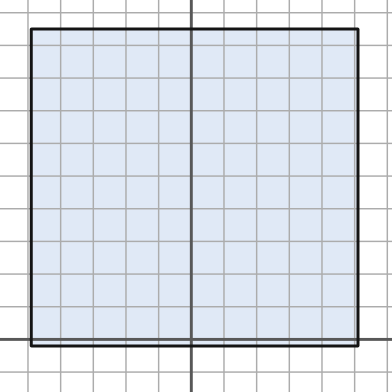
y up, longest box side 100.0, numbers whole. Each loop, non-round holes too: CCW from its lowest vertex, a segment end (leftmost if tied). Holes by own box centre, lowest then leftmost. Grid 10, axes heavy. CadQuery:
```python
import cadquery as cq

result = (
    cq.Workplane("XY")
    .moveTo(-49.0, -2.0)
    .lineTo(51.0, -2.0)
    .lineTo(51.0, 95.0)
    .lineTo(-49.0, 95.0)
    .close()
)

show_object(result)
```